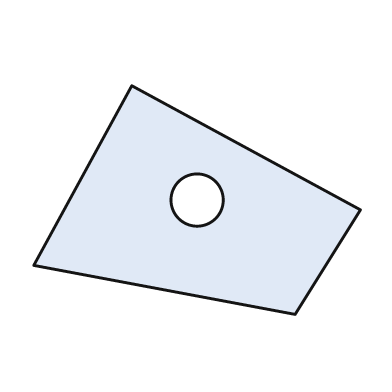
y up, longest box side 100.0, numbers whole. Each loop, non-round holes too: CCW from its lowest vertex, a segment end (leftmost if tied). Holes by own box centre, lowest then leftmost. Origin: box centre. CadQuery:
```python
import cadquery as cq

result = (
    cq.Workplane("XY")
    .moveTo(30.0, -35.0)
    .lineTo(50.0, -3.0)
    .lineTo(-20.0, 35.0)
    .lineTo(-50.0, -20.0)
    .close()
    .moveTo(0.0, 0.0)
    .circle(8.0)
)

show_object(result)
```